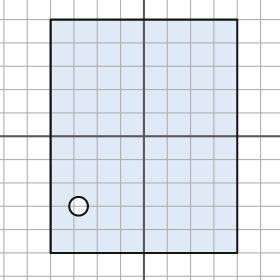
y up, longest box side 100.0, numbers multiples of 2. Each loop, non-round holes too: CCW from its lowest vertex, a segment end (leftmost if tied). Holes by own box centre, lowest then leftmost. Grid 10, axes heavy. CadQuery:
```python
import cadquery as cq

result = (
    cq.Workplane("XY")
    .moveTo(-40.0, -50.0)
    .lineTo(40.0, -50.0)
    .lineTo(40.0, 50.0)
    .lineTo(-40.0, 50.0)
    .close()
    .moveTo(-28.0, -30.0)
    .circle(4.0)
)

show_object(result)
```